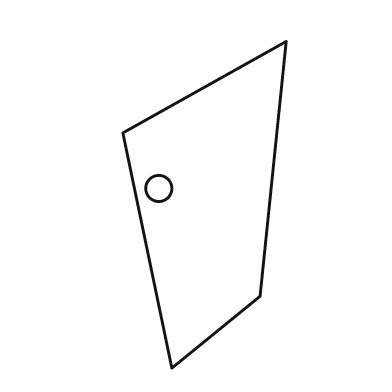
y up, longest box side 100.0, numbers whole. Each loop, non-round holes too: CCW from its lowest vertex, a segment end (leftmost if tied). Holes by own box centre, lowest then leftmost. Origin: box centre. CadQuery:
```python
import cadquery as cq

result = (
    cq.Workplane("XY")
    .moveTo(-10.0, -50.0)
    .lineTo(17.0, -28.0)
    .lineTo(25.0, 50.0)
    .lineTo(-25.0, 22.0)
    .close()
    .moveTo(-14.0, 5.0)
    .circle(4.0)
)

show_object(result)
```